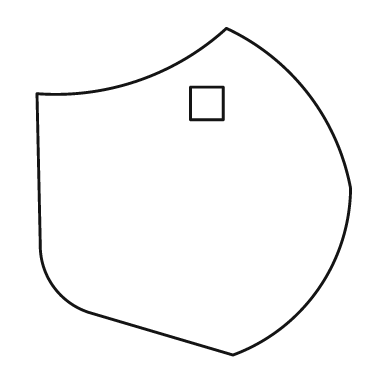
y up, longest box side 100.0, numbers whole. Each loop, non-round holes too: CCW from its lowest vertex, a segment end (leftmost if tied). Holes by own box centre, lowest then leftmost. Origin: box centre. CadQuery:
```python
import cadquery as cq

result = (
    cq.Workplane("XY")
    .moveTo(12.0, -50.0)
    .threePointArc((38.0, -30.0), (48.0, 1.0))
    .threePointArc((35.0, 30.0), (10.0, 50.0))
    .threePointArc((-17.0, 34.0), (-48.0, 30.0))
    .lineTo(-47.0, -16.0)
    .threePointArc((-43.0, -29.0), (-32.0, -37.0))
    .close()
    .moveTo(-1.0, 22.0)
    .lineTo(9.0, 22.0)
    .lineTo(9.0, 32.0)
    .lineTo(-1.0, 32.0)
    .close()
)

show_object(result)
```